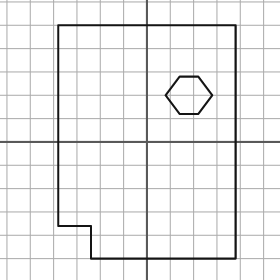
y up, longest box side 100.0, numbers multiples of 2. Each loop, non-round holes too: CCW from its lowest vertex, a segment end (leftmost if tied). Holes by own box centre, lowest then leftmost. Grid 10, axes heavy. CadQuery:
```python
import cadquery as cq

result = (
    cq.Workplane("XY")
    .moveTo(-24.0, -50.0)
    .lineTo(38.0, -50.0)
    .lineTo(38.0, 50.0)
    .lineTo(-38.0, 50.0)
    .lineTo(-38.0, -36.0)
    .lineTo(-24.0, -36.0)
    .close()
    .moveTo(14.0, 12.0)
    .lineTo(22.0, 12.0)
    .lineTo(28.0, 20.0)
    .lineTo(22.0, 28.0)
    .lineTo(14.0, 28.0)
    .lineTo(8.0, 20.0)
    .close()
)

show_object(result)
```